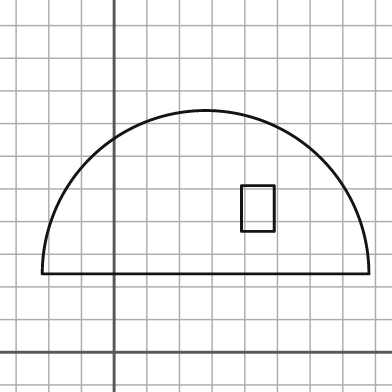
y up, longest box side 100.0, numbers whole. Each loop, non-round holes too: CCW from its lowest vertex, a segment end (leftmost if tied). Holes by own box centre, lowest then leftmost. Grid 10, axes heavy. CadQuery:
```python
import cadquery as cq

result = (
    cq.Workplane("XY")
    .moveTo(-22.0, 24.0)
    .lineTo(78.0, 24.0)
    .threePointArc((28.0, 74.0), (-22.0, 24.0))
    .close()
    .moveTo(39.0, 37.0)
    .lineTo(49.0, 37.0)
    .lineTo(49.0, 51.0)
    .lineTo(39.0, 51.0)
    .close()
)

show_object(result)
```